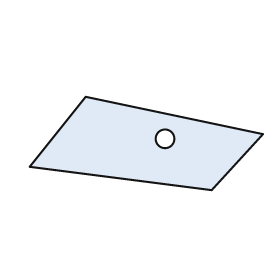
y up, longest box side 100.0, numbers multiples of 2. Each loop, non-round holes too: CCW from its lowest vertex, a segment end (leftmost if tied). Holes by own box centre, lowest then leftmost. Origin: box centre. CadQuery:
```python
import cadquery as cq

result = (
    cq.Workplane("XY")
    .moveTo(28.0, -20.0)
    .lineTo(50.0, 4.0)
    .lineTo(-26.0, 20.0)
    .lineTo(-50.0, -10.0)
    .close()
    .moveTo(8.0, 2.0)
    .circle(4.0)
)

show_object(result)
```